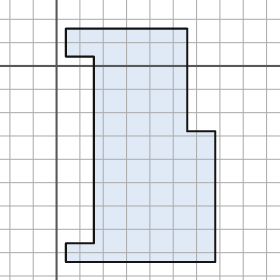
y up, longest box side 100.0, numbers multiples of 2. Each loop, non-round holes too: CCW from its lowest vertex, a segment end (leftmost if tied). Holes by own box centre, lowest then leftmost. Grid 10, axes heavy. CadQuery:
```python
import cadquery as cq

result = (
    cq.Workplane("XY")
    .moveTo(4.0, -84.0)
    .lineTo(68.0, -84.0)
    .lineTo(68.0, -28.0)
    .lineTo(56.0, -28.0)
    .lineTo(56.0, 16.0)
    .lineTo(4.0, 16.0)
    .lineTo(4.0, 4.0)
    .lineTo(16.0, 4.0)
    .lineTo(16.0, -76.0)
    .lineTo(4.0, -76.0)
    .close()
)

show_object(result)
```